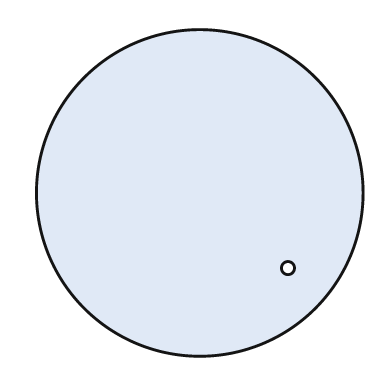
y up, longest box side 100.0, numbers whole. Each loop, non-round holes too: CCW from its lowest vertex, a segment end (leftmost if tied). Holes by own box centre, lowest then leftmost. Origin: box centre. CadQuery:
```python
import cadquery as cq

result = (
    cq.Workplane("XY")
    .moveTo(0.0, 0.0)
    .circle(50.0)
    .moveTo(27.0, -23.0)
    .circle(2.0)
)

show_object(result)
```